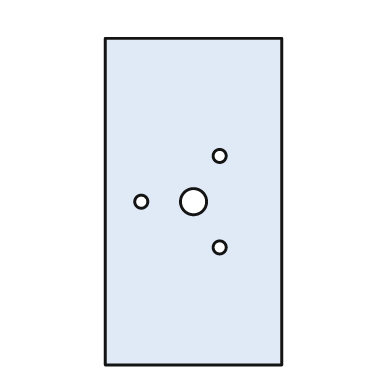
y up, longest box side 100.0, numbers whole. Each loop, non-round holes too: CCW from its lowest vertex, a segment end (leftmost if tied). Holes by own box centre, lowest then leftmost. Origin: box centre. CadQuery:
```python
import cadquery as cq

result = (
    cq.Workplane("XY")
    .moveTo(-27.0, -50.0)
    .lineTo(27.0, -50.0)
    .lineTo(27.0, 50.0)
    .lineTo(-27.0, 50.0)
    .close()
    .moveTo(8.0, -14.0)
    .circle(2.0)
    .moveTo(-16.0, 0.0)
    .circle(2.0)
    .moveTo(0.0, 0.0)
    .circle(4.0)
    .moveTo(8.0, 14.0)
    .circle(2.0)
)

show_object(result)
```